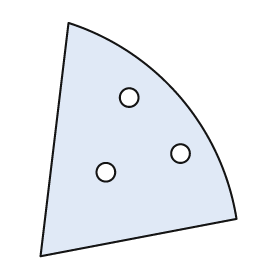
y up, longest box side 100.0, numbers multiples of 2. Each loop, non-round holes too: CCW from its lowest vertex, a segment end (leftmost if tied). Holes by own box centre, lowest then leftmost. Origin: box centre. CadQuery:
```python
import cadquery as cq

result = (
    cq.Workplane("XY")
    .moveTo(-42.0, -50.0)
    .lineTo(42.0, -34.0)
    .threePointArc((18.0, 18.0), (-30.0, 50.0))
    .close()
    .moveTo(-14.0, -14.0)
    .circle(4.0)
    .moveTo(18.0, -6.0)
    .circle(4.0)
    .moveTo(-4.0, 18.0)
    .circle(4.0)
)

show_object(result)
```